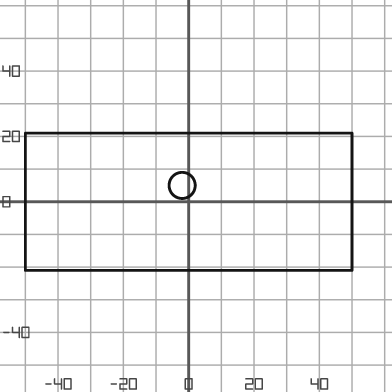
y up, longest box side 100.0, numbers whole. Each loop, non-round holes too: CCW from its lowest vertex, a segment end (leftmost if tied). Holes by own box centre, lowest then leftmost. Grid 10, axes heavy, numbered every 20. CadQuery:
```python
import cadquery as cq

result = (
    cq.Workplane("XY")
    .moveTo(-50.0, -21.0)
    .lineTo(50.0, -21.0)
    .lineTo(50.0, 21.0)
    .lineTo(-50.0, 21.0)
    .close()
    .moveTo(-2.0, 5.0)
    .circle(4.0)
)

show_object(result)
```